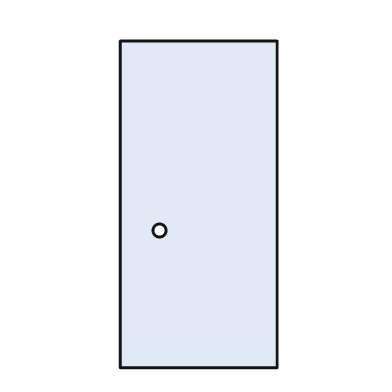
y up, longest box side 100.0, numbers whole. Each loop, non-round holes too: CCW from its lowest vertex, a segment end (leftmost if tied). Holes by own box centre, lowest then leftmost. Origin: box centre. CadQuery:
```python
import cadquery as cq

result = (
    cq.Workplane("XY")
    .moveTo(-24.0, -50.0)
    .lineTo(24.0, -50.0)
    .lineTo(24.0, 50.0)
    .lineTo(-24.0, 50.0)
    .close()
    .moveTo(-12.0, -8.0)
    .circle(2.0)
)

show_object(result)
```